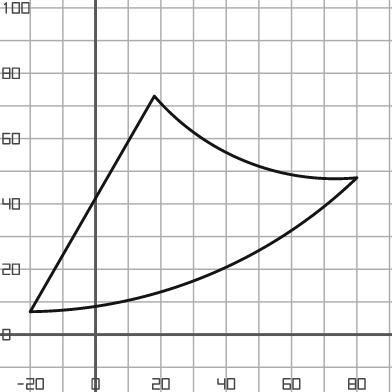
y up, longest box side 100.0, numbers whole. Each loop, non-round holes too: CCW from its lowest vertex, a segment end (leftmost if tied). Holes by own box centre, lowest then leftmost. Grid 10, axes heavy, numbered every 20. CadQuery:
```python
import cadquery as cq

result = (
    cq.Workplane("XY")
    .moveTo(-20.0, 7.0)
    .threePointArc((34.0, 18.0), (80.0, 48.0))
    .threePointArc((46.0, 53.0), (18.0, 73.0))
    .close()
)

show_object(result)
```